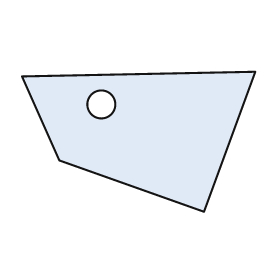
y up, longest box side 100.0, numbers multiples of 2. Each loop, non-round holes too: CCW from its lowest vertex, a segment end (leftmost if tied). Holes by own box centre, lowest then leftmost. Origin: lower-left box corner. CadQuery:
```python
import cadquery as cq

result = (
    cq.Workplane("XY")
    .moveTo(78.0, 0.0)
    .lineTo(100.0, 60.0)
    .lineTo(0.0, 58.0)
    .lineTo(16.0, 22.0)
    .close()
    .moveTo(34.0, 46.0)
    .circle(6.0)
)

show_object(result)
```